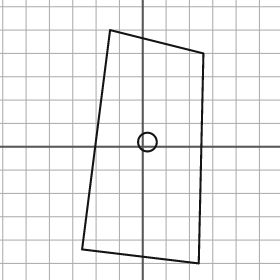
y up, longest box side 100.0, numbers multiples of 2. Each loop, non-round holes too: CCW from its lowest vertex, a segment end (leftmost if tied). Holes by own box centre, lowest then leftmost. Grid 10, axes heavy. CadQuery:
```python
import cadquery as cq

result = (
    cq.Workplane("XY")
    .moveTo(24.0, -50.0)
    .lineTo(26.0, 40.0)
    .lineTo(-14.0, 50.0)
    .lineTo(-26.0, -44.0)
    .close()
    .moveTo(2.0, 2.0)
    .circle(4.0)
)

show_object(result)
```